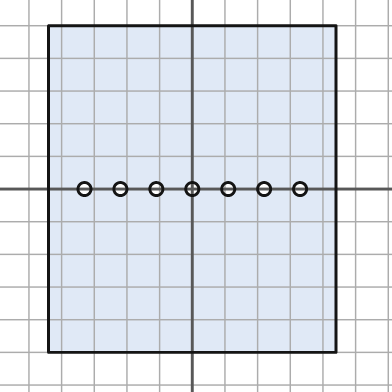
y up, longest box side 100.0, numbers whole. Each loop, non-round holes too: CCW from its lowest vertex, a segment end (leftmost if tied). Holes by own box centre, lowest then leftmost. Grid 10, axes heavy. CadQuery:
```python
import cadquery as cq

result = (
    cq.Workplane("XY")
    .moveTo(-44.0, -50.0)
    .lineTo(44.0, -50.0)
    .lineTo(44.0, 50.0)
    .lineTo(-44.0, 50.0)
    .close()
    .moveTo(-33.0, 0.0)
    .circle(2.0)
    .moveTo(-22.0, 0.0)
    .circle(2.0)
    .moveTo(-11.0, 0.0)
    .circle(2.0)
    .moveTo(0.0, 0.0)
    .circle(2.0)
    .moveTo(11.0, 0.0)
    .circle(2.0)
    .moveTo(22.0, 0.0)
    .circle(2.0)
    .moveTo(33.0, 0.0)
    .circle(2.0)
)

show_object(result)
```